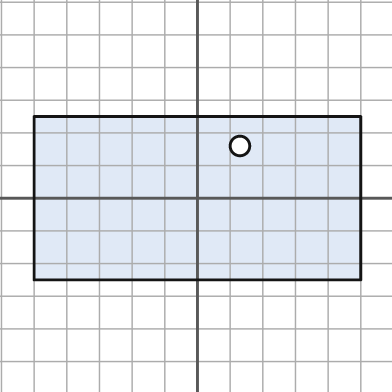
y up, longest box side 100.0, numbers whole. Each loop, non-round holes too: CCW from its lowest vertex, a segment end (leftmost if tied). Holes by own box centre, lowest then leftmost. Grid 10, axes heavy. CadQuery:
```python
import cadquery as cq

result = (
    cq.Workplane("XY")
    .moveTo(-50.0, -25.0)
    .lineTo(50.0, -25.0)
    .lineTo(50.0, 25.0)
    .lineTo(-50.0, 25.0)
    .close()
    .moveTo(13.0, 16.0)
    .circle(3.0)
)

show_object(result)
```